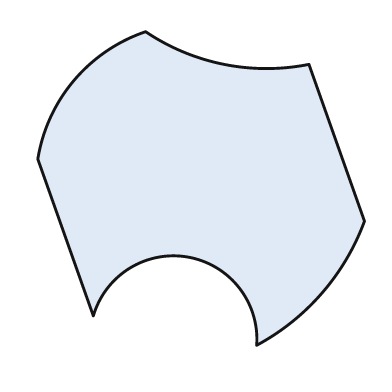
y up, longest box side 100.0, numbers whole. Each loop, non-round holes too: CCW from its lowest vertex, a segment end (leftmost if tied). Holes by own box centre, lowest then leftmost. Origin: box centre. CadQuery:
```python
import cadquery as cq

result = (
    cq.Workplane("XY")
    .moveTo(17.0, -48.0)
    .threePointArc((37.0, -32.0), (50.0, -10.0))
    .lineTo(33.0, 38.0)
    .threePointArc((7.0, 38.0), (-17.0, 48.0))
    .threePointArc((-39.0, 33.0), (-50.0, 9.0))
    .lineTo(-33.0, -39.0)
    .threePointArc((-4.0, -21.0), (17.0, -48.0))
    .close()
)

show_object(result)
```